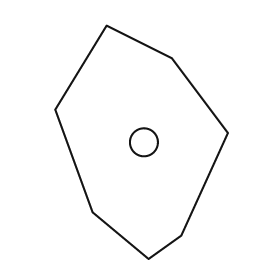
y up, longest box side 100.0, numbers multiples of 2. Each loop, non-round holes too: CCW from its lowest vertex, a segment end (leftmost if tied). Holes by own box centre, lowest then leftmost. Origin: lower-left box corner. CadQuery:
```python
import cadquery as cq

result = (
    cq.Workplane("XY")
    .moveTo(40.0, 0.0)
    .lineTo(54.0, 10.0)
    .lineTo(74.0, 54.0)
    .lineTo(50.0, 86.0)
    .lineTo(22.0, 100.0)
    .lineTo(0.0, 64.0)
    .lineTo(16.0, 20.0)
    .close()
    .moveTo(38.0, 50.0)
    .circle(6.0)
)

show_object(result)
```